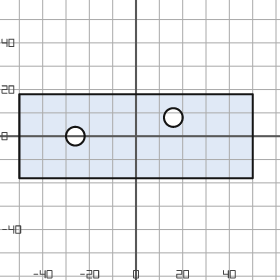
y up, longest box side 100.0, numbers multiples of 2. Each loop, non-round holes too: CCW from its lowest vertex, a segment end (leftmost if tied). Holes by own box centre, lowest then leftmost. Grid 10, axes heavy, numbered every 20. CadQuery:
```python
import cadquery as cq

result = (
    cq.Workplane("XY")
    .moveTo(-50.0, -18.0)
    .lineTo(50.0, -18.0)
    .lineTo(50.0, 18.0)
    .lineTo(-50.0, 18.0)
    .close()
    .moveTo(-26.0, 0.0)
    .circle(4.0)
    .moveTo(16.0, 8.0)
    .circle(4.0)
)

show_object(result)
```